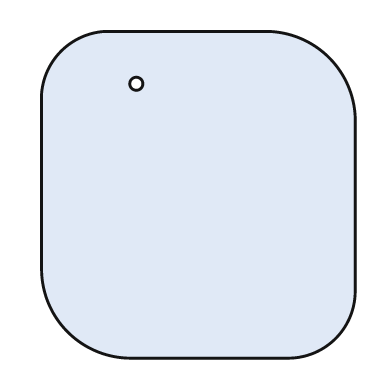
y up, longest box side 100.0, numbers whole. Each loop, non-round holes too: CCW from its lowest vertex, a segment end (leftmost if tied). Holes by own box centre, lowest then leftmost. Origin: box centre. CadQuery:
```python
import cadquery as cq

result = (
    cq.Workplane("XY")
    .moveTo(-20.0, -50.0)
    .lineTo(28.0, -50.0)
    .threePointArc((42.0, -44.0), (48.0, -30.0))
    .lineTo(48.0, 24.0)
    .threePointArc((40.0, 42.0), (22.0, 50.0))
    .lineTo(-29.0, 50.0)
    .threePointArc((-42.0, 44.0), (-48.0, 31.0))
    .lineTo(-48.0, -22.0)
    .threePointArc((-40.0, -42.0), (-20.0, -50.0))
    .close()
    .moveTo(-19.0, 34.0)
    .circle(2.0)
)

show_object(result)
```